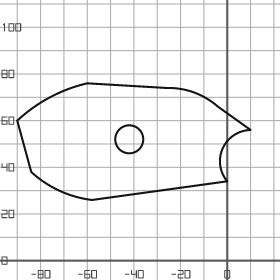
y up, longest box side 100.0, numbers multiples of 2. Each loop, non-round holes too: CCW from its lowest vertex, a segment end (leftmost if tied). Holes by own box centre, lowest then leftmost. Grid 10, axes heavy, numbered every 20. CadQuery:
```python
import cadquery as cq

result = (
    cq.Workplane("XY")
    .moveTo(-58.0, 26.0)
    .lineTo(0.0, 34.0)
    .threePointArc((-2.0, 48.0), (10.0, 56.0))
    .lineTo(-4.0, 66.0)
    .threePointArc((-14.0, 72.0), (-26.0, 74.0))
    .lineTo(-60.0, 76.0)
    .threePointArc((-76.0, 70.0), (-90.0, 60.0))
    .lineTo(-84.0, 38.0)
    .threePointArc((-72.0, 30.0), (-58.0, 26.0))
    .close()
    .moveTo(-42.0, 52.0)
    .circle(6.0)
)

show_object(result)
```